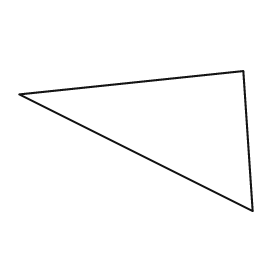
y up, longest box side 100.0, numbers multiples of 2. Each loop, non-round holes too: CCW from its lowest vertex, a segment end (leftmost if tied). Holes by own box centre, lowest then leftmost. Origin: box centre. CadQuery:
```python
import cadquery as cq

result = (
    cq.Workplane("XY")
    .moveTo(50.0, -30.0)
    .lineTo(46.0, 30.0)
    .lineTo(-50.0, 20.0)
    .close()
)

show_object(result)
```